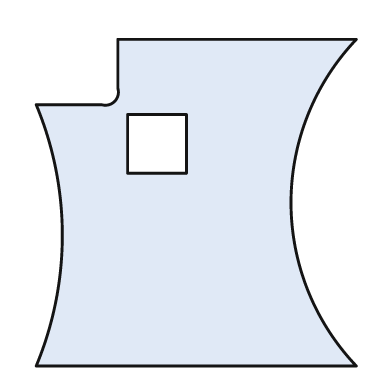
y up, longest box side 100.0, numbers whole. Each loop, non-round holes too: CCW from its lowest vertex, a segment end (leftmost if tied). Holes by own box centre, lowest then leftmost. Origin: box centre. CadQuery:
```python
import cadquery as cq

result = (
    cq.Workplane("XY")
    .moveTo(-49.0, -50.0)
    .lineTo(49.0, -50.0)
    .threePointArc((29.0, 0.0), (49.0, 50.0))
    .lineTo(-24.0, 50.0)
    .lineTo(-24.0, 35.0)
    .threePointArc((-25.0, 31.0), (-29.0, 30.0))
    .lineTo(-49.0, 30.0)
    .threePointArc((-41.0, -10.0), (-49.0, -50.0))
    .close()
    .moveTo(-21.0, 9.0)
    .lineTo(-3.0, 9.0)
    .lineTo(-3.0, 27.0)
    .lineTo(-21.0, 27.0)
    .close()
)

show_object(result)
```